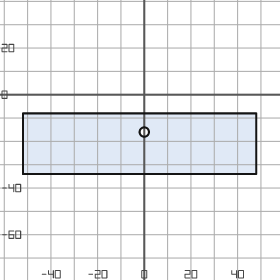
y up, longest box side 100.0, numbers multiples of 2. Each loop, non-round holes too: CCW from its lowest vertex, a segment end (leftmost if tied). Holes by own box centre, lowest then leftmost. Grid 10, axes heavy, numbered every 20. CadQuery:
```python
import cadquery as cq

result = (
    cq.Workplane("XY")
    .moveTo(-52.0, -34.0)
    .lineTo(48.0, -34.0)
    .lineTo(48.0, -8.0)
    .lineTo(-52.0, -8.0)
    .close()
    .moveTo(0.0, -16.0)
    .circle(2.0)
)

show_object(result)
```